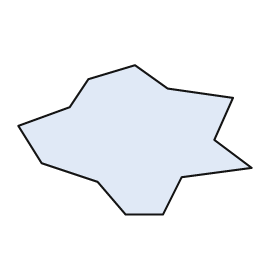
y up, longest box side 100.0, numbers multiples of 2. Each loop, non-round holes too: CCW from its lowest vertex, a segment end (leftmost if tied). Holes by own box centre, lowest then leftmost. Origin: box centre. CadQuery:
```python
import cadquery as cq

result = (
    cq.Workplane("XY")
    .moveTo(-4.0, -32.0)
    .lineTo(12.0, -32.0)
    .lineTo(20.0, -16.0)
    .lineTo(50.0, -12.0)
    .lineTo(34.0, 0.0)
    .lineTo(42.0, 18.0)
    .lineTo(14.0, 22.0)
    .lineTo(0.0, 32.0)
    .lineTo(-20.0, 26.0)
    .lineTo(-28.0, 14.0)
    .lineTo(-50.0, 6.0)
    .lineTo(-40.0, -10.0)
    .lineTo(-16.0, -18.0)
    .close()
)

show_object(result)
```